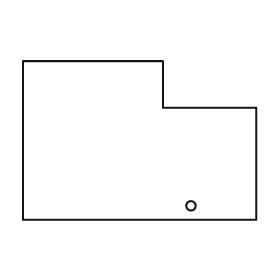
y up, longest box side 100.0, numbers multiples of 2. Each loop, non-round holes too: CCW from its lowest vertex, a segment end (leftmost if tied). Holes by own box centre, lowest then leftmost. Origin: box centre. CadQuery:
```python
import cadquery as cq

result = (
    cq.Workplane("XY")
    .moveTo(-50.0, -34.0)
    .lineTo(50.0, -34.0)
    .lineTo(50.0, 14.0)
    .lineTo(10.0, 14.0)
    .lineTo(10.0, 34.0)
    .lineTo(-50.0, 34.0)
    .close()
    .moveTo(22.0, -28.0)
    .circle(2.0)
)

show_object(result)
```